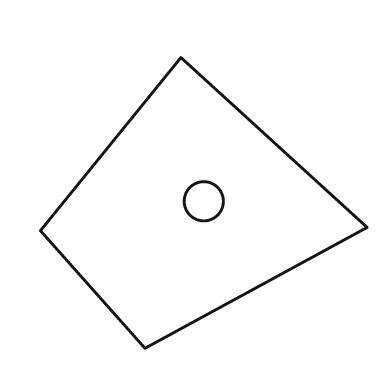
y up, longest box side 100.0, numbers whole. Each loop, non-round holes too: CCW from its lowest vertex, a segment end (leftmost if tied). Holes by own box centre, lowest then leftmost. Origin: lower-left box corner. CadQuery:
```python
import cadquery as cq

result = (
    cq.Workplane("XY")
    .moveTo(32.0, 0.0)
    .lineTo(100.0, 37.0)
    .lineTo(43.0, 89.0)
    .lineTo(0.0, 36.0)
    .close()
    .moveTo(50.0, 45.0)
    .circle(6.0)
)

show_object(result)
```